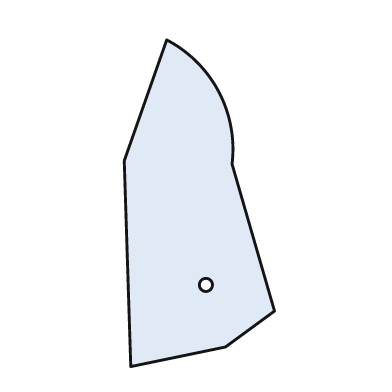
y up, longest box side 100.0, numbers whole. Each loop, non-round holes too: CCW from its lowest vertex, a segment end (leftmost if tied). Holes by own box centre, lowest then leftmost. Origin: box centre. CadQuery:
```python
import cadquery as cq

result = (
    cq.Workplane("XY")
    .moveTo(-21.0, -50.0)
    .lineTo(8.0, -44.0)
    .lineTo(23.0, -33.0)
    .lineTo(10.0, 12.0)
    .threePointArc((6.0, 34.0), (-10.0, 50.0))
    .lineTo(-23.0, 13.0)
    .close()
    .moveTo(2.0, -25.0)
    .circle(2.0)
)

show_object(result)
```